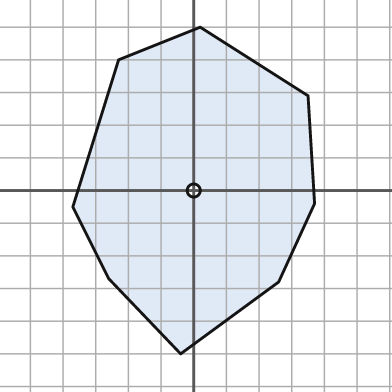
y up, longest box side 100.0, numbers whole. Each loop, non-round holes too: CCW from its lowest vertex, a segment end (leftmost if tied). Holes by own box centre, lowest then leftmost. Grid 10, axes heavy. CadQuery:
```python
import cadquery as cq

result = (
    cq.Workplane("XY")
    .moveTo(-4.0, -50.0)
    .lineTo(26.0, -28.0)
    .lineTo(37.0, -4.0)
    .lineTo(35.0, 29.0)
    .lineTo(2.0, 50.0)
    .lineTo(-23.0, 40.0)
    .lineTo(-37.0, -5.0)
    .lineTo(-26.0, -27.0)
    .close()
    .moveTo(0.0, 0.0)
    .circle(2.0)
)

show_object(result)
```